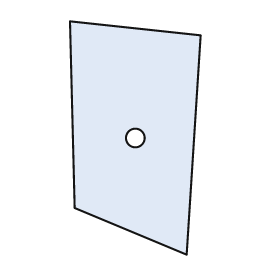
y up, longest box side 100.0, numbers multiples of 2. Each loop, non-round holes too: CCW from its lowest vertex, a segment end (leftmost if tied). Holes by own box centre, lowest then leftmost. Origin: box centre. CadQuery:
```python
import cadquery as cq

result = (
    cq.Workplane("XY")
    .moveTo(22.0, -50.0)
    .lineTo(28.0, 44.0)
    .lineTo(-28.0, 50.0)
    .lineTo(-26.0, -30.0)
    .close()
    .moveTo(0.0, 0.0)
    .circle(4.0)
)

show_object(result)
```